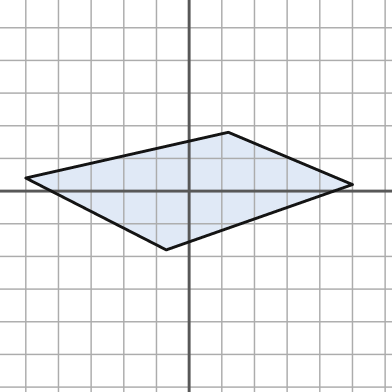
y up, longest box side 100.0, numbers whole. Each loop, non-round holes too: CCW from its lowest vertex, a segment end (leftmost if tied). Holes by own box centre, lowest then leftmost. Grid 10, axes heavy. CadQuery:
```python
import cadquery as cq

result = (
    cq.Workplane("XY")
    .moveTo(-7.0, -18.0)
    .lineTo(50.0, 2.0)
    .lineTo(12.0, 18.0)
    .lineTo(-50.0, 4.0)
    .close()
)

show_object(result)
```